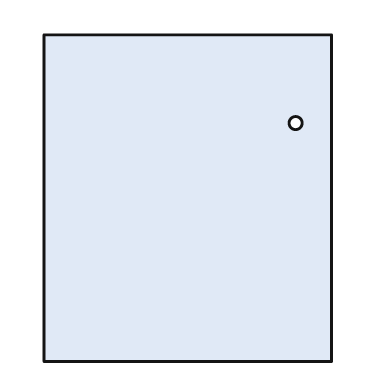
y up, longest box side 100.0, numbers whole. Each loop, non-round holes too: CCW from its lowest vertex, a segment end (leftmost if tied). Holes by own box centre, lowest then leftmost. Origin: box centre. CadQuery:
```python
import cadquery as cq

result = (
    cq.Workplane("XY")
    .moveTo(-44.0, -50.0)
    .lineTo(44.0, -50.0)
    .lineTo(44.0, 50.0)
    .lineTo(-44.0, 50.0)
    .close()
    .moveTo(33.0, 23.0)
    .circle(2.0)
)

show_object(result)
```